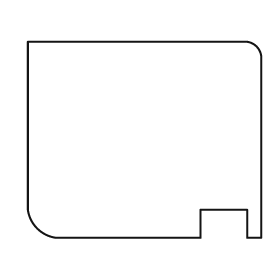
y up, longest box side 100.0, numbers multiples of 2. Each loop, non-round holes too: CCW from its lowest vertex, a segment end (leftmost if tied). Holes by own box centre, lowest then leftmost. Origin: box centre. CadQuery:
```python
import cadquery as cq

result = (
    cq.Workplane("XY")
    .moveTo(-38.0, -42.0)
    .lineTo(24.0, -42.0)
    .lineTo(24.0, -30.0)
    .lineTo(44.0, -30.0)
    .lineTo(44.0, -42.0)
    .lineTo(50.0, -42.0)
    .lineTo(50.0, 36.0)
    .threePointArc((48.0, 40.0), (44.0, 42.0))
    .lineTo(-50.0, 42.0)
    .lineTo(-50.0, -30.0)
    .threePointArc((-46.0, -38.0), (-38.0, -42.0))
    .close()
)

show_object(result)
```